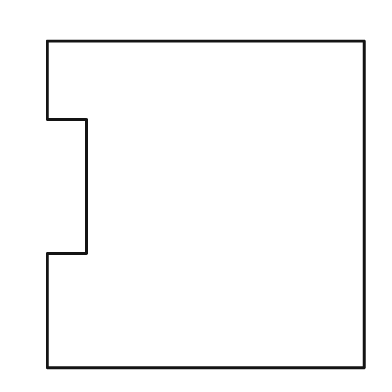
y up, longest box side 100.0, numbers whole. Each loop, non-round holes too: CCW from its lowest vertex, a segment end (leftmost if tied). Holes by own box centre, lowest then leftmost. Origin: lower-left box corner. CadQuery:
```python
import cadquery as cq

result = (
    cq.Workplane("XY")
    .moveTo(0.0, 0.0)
    .lineTo(97.0, 0.0)
    .lineTo(97.0, 100.0)
    .lineTo(0.0, 100.0)
    .lineTo(0.0, 76.0)
    .lineTo(12.0, 76.0)
    .lineTo(12.0, 35.0)
    .lineTo(0.0, 35.0)
    .close()
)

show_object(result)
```